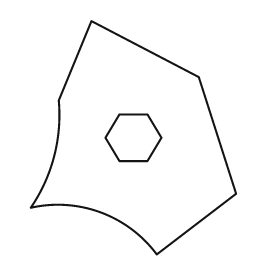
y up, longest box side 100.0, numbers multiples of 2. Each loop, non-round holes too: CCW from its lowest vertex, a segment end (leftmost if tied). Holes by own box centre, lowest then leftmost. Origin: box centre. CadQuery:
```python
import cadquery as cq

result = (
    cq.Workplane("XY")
    .moveTo(10.0, -50.0)
    .lineTo(44.0, -24.0)
    .lineTo(28.0, 26.0)
    .lineTo(-18.0, 50.0)
    .lineTo(-32.0, 16.0)
    .threePointArc((-34.0, -8.0), (-44.0, -30.0))
    .threePointArc((-14.0, -32.0), (10.0, -50.0))
    .close()
    .moveTo(-6.0, -10.0)
    .lineTo(6.0, -10.0)
    .lineTo(12.0, 0.0)
    .lineTo(6.0, 10.0)
    .lineTo(-6.0, 10.0)
    .lineTo(-12.0, 0.0)
    .close()
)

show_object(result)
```